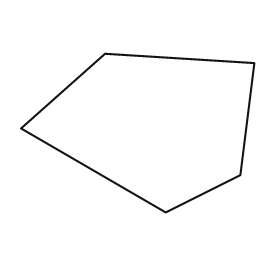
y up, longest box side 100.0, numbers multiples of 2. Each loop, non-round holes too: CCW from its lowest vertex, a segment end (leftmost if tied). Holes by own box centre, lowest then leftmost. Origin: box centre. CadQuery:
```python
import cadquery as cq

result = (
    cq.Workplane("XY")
    .moveTo(12.0, -34.0)
    .lineTo(44.0, -18.0)
    .lineTo(50.0, 30.0)
    .lineTo(-14.0, 34.0)
    .lineTo(-50.0, 2.0)
    .close()
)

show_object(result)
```